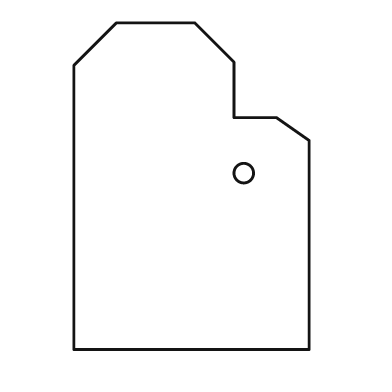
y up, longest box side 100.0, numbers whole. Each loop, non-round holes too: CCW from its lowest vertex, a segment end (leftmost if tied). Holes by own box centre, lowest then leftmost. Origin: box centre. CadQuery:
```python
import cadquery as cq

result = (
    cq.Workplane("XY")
    .moveTo(-36.0, -50.0)
    .lineTo(36.0, -50.0)
    .lineTo(36.0, 14.0)
    .lineTo(26.0, 21.0)
    .lineTo(13.0, 21.0)
    .lineTo(13.0, 38.0)
    .lineTo(1.0, 50.0)
    .lineTo(-23.0, 50.0)
    .lineTo(-36.0, 37.0)
    .close()
    .moveTo(16.0, 4.0)
    .circle(3.0)
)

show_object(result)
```